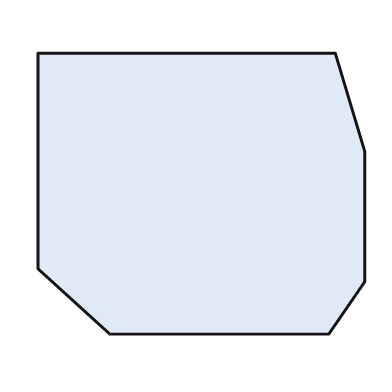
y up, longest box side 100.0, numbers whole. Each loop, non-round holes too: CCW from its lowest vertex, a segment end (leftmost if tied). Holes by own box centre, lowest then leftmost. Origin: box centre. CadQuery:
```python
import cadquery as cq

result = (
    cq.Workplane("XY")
    .moveTo(-28.0, -43.0)
    .lineTo(39.0, -43.0)
    .lineTo(50.0, -27.0)
    .lineTo(50.0, 13.0)
    .lineTo(41.0, 43.0)
    .lineTo(-50.0, 43.0)
    .lineTo(-50.0, -23.0)
    .close()
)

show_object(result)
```